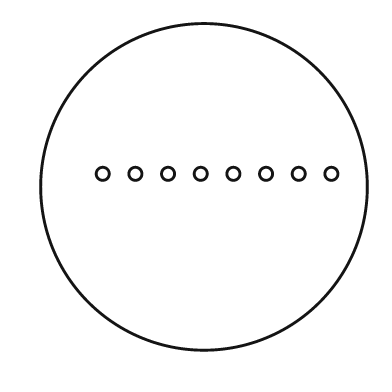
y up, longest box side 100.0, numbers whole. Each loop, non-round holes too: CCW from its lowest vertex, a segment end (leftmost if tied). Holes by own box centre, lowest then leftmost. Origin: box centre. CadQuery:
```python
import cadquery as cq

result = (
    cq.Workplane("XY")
    .moveTo(0.0, 0.0)
    .circle(50.0)
    .moveTo(-31.0, 4.0)
    .circle(2.0)
    .moveTo(-21.0, 4.0)
    .circle(2.0)
    .moveTo(-11.0, 4.0)
    .circle(2.0)
    .moveTo(-1.0, 4.0)
    .circle(2.0)
    .moveTo(9.0, 4.0)
    .circle(2.0)
    .moveTo(19.0, 4.0)
    .circle(2.0)
    .moveTo(29.0, 4.0)
    .circle(2.0)
    .moveTo(39.0, 4.0)
    .circle(2.0)
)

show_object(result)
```